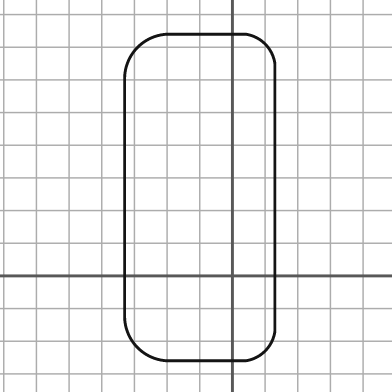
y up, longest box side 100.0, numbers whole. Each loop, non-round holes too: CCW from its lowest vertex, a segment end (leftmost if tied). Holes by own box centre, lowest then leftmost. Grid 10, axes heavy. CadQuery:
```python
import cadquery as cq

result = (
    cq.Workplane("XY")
    .moveTo(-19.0, -26.0)
    .lineTo(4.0, -26.0)
    .threePointArc((10.0, -23.0), (13.0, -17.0))
    .lineTo(13.0, 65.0)
    .threePointArc((10.0, 71.0), (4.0, 74.0))
    .lineTo(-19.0, 74.0)
    .threePointArc((-29.0, 70.0), (-33.0, 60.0))
    .lineTo(-33.0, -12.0)
    .threePointArc((-29.0, -22.0), (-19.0, -26.0))
    .close()
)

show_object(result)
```